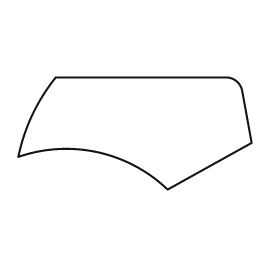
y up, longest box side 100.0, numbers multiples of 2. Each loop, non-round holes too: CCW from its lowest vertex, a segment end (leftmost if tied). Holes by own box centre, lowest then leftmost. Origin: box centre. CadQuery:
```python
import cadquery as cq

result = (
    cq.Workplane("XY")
    .moveTo(14.0, -24.0)
    .lineTo(50.0, -4.0)
    .lineTo(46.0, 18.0)
    .threePointArc((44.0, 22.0), (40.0, 24.0))
    .lineTo(-34.0, 24.0)
    .threePointArc((-44.0, 8.0), (-50.0, -10.0))
    .threePointArc((-16.0, -8.0), (14.0, -24.0))
    .close()
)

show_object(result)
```